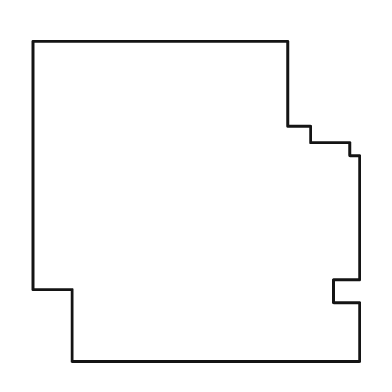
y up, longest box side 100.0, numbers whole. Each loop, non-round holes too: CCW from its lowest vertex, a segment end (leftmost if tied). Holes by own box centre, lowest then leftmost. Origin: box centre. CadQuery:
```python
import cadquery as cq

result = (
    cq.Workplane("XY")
    .moveTo(-38.0, -49.0)
    .lineTo(50.0, -49.0)
    .lineTo(50.0, -31.0)
    .lineTo(42.0, -31.0)
    .lineTo(42.0, -24.0)
    .lineTo(50.0, -24.0)
    .lineTo(50.0, 14.0)
    .lineTo(47.0, 14.0)
    .lineTo(47.0, 18.0)
    .lineTo(35.0, 18.0)
    .lineTo(35.0, 23.0)
    .lineTo(28.0, 23.0)
    .lineTo(28.0, 49.0)
    .lineTo(-50.0, 49.0)
    .lineTo(-50.0, -27.0)
    .lineTo(-38.0, -27.0)
    .close()
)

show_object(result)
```